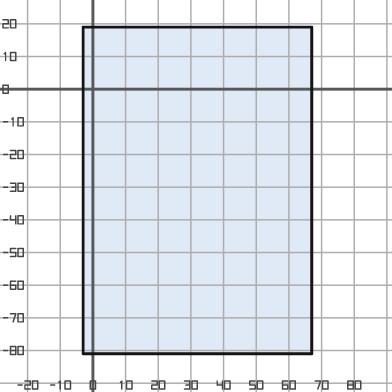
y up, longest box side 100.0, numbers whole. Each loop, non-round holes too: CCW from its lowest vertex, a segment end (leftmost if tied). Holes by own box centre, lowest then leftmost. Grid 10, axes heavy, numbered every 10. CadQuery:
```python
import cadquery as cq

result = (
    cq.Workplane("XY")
    .moveTo(-3.0, -81.0)
    .lineTo(67.0, -81.0)
    .lineTo(67.0, 19.0)
    .lineTo(-3.0, 19.0)
    .close()
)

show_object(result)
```